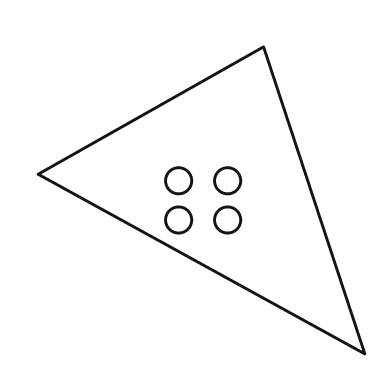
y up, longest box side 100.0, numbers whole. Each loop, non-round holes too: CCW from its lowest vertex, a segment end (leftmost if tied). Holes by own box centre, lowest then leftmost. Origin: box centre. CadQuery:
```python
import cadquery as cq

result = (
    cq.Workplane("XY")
    .moveTo(50.0, -47.0)
    .lineTo(19.0, 47.0)
    .lineTo(-50.0, 8.0)
    .close()
    .moveTo(-7.0, -6.0)
    .circle(4.0)
    .moveTo(8.0, -6.0)
    .circle(4.0)
    .moveTo(-7.0, 6.0)
    .circle(4.0)
    .moveTo(8.0, 6.0)
    .circle(4.0)
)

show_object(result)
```